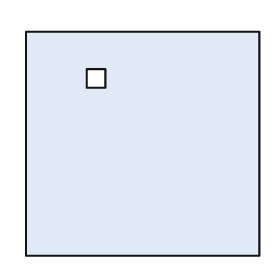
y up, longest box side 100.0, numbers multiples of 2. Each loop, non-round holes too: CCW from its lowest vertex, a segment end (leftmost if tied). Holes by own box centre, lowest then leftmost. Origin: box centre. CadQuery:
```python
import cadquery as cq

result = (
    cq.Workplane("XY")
    .moveTo(-50.0, -48.0)
    .lineTo(50.0, -48.0)
    .lineTo(50.0, 48.0)
    .lineTo(-50.0, 48.0)
    .close()
    .moveTo(-24.0, 24.0)
    .lineTo(-16.0, 24.0)
    .lineTo(-16.0, 32.0)
    .lineTo(-24.0, 32.0)
    .close()
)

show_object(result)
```